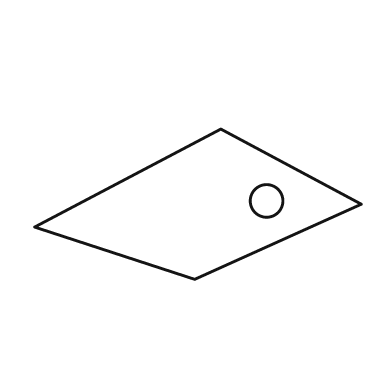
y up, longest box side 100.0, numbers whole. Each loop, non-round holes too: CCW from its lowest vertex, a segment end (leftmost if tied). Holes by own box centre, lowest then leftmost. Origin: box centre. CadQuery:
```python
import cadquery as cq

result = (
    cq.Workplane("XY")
    .moveTo(-1.0, -23.0)
    .lineTo(50.0, 0.0)
    .lineTo(7.0, 23.0)
    .lineTo(-50.0, -7.0)
    .close()
    .moveTo(21.0, 1.0)
    .circle(5.0)
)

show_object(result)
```